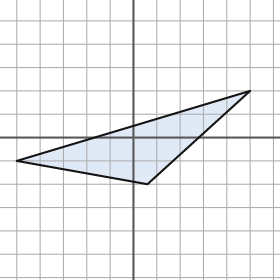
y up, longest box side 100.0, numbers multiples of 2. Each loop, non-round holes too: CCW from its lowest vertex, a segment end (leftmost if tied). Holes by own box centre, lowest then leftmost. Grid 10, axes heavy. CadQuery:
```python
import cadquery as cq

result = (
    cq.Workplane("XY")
    .moveTo(6.0, -20.0)
    .lineTo(50.0, 20.0)
    .lineTo(-50.0, -10.0)
    .close()
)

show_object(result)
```